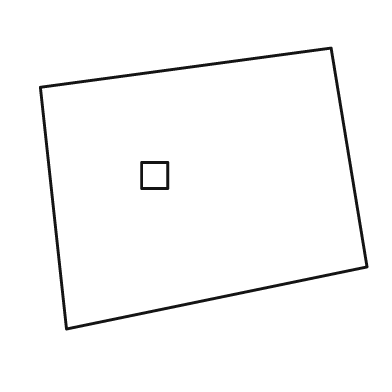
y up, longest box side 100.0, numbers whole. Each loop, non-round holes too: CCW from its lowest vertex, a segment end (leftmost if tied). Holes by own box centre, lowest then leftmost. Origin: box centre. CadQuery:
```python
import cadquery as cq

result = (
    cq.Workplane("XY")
    .moveTo(-42.0, -43.0)
    .lineTo(50.0, -24.0)
    .lineTo(39.0, 43.0)
    .lineTo(-50.0, 31.0)
    .close()
    .moveTo(-19.0, 0.0)
    .lineTo(-11.0, 0.0)
    .lineTo(-11.0, 8.0)
    .lineTo(-19.0, 8.0)
    .close()
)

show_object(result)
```